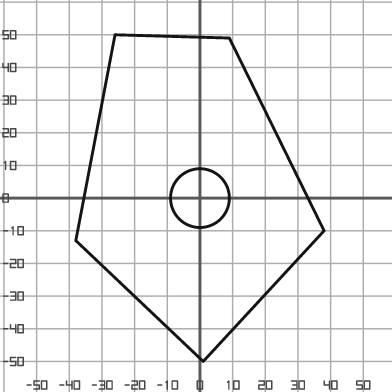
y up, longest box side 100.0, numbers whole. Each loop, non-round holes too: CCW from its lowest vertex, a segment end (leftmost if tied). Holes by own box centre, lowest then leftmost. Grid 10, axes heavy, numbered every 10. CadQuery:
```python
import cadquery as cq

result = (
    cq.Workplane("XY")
    .moveTo(1.0, -50.0)
    .lineTo(38.0, -10.0)
    .lineTo(9.0, 49.0)
    .lineTo(-26.0, 50.0)
    .lineTo(-38.0, -13.0)
    .close()
    .moveTo(0.0, 0.0)
    .circle(9.0)
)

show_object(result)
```